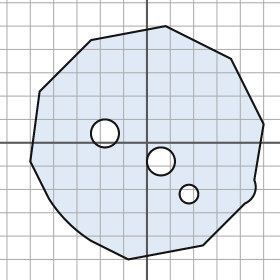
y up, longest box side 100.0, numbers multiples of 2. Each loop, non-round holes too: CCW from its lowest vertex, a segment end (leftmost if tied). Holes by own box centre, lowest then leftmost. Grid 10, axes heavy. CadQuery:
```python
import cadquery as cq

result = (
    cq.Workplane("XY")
    .moveTo(-8.0, -50.0)
    .lineTo(24.0, -44.0)
    .lineTo(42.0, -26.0)
    .threePointArc((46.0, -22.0), (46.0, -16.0))
    .lineTo(50.0, 8.0)
    .lineTo(36.0, 36.0)
    .lineTo(8.0, 50.0)
    .lineTo(-24.0, 44.0)
    .lineTo(-46.0, 22.0)
    .lineTo(-50.0, -8.0)
    .lineTo(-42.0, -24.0)
    .threePointArc((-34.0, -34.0), (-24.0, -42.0))
    .close()
    .moveTo(18.0, -22.0)
    .circle(4.0)
    .moveTo(6.0, -8.0)
    .circle(6.0)
    .moveTo(-18.0, 4.0)
    .circle(6.0)
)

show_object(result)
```